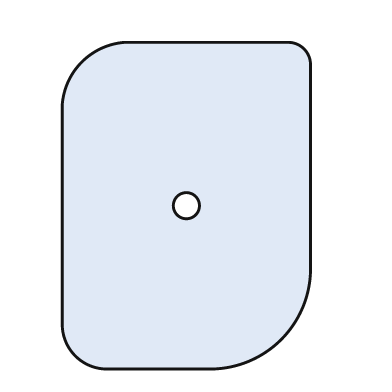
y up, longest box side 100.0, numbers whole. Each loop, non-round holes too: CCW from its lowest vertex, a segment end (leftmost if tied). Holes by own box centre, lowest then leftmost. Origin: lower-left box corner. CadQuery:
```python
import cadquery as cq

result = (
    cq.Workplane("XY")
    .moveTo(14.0, 0.0)
    .lineTo(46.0, 0.0)
    .threePointArc((67.0, 9.0), (76.0, 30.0))
    .lineTo(76.0, 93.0)
    .threePointArc((74.0, 98.0), (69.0, 100.0))
    .lineTo(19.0, 100.0)
    .threePointArc((6.0, 94.0), (0.0, 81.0))
    .lineTo(0.0, 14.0)
    .threePointArc((4.0, 4.0), (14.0, 0.0))
    .close()
    .moveTo(38.0, 50.0)
    .circle(4.0)
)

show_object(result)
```